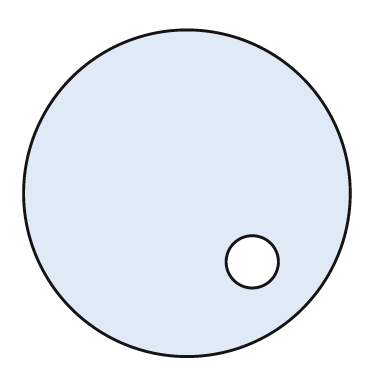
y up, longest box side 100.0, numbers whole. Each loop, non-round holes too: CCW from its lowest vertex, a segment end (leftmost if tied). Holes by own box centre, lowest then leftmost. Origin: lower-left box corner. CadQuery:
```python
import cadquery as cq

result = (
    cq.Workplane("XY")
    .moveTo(50.0, 50.0)
    .circle(50.0)
    .moveTo(70.0, 29.0)
    .circle(8.0)
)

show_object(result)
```